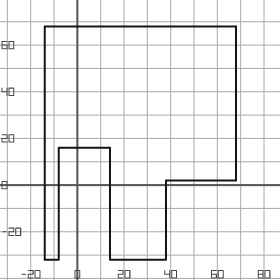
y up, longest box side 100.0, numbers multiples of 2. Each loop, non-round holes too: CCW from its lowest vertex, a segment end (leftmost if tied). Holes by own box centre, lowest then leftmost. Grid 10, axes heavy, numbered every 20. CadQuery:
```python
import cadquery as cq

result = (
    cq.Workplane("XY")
    .moveTo(-14.0, -32.0)
    .lineTo(-8.0, -32.0)
    .lineTo(-8.0, 16.0)
    .lineTo(14.0, 16.0)
    .lineTo(14.0, -32.0)
    .lineTo(38.0, -32.0)
    .lineTo(38.0, 2.0)
    .lineTo(68.0, 2.0)
    .lineTo(68.0, 68.0)
    .lineTo(-14.0, 68.0)
    .close()
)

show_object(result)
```